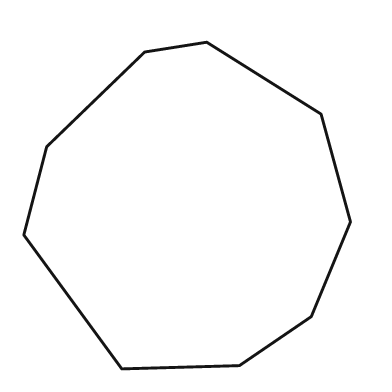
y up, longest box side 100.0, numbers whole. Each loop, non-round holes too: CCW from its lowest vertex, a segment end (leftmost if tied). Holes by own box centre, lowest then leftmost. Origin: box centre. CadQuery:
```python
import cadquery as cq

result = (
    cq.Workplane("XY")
    .moveTo(-20.0, -50.0)
    .lineTo(16.0, -49.0)
    .lineTo(38.0, -34.0)
    .lineTo(50.0, -5.0)
    .lineTo(41.0, 28.0)
    .lineTo(6.0, 50.0)
    .lineTo(-13.0, 47.0)
    .lineTo(-43.0, 18.0)
    .lineTo(-50.0, -9.0)
    .close()
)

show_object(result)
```